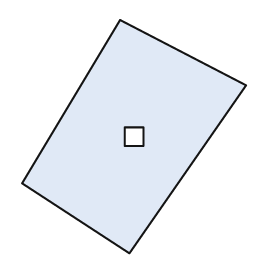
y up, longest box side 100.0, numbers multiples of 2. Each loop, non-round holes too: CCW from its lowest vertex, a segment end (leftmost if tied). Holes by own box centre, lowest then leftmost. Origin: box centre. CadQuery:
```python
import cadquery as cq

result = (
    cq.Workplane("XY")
    .moveTo(-2.0, -50.0)
    .lineTo(48.0, 22.0)
    .lineTo(-6.0, 50.0)
    .lineTo(-48.0, -20.0)
    .close()
    .moveTo(-4.0, -4.0)
    .lineTo(4.0, -4.0)
    .lineTo(4.0, 4.0)
    .lineTo(-4.0, 4.0)
    .close()
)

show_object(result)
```